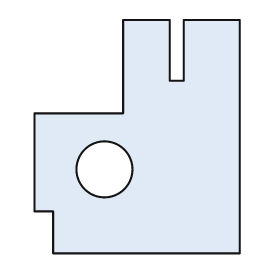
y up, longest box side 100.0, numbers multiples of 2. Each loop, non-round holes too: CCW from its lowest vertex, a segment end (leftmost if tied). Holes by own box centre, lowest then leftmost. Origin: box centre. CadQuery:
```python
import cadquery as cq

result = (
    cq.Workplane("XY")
    .moveTo(-36.0, -50.0)
    .lineTo(44.0, -50.0)
    .lineTo(44.0, 50.0)
    .lineTo(20.0, 50.0)
    .lineTo(20.0, 24.0)
    .lineTo(14.0, 24.0)
    .lineTo(14.0, 50.0)
    .lineTo(-6.0, 50.0)
    .lineTo(-6.0, 10.0)
    .lineTo(-44.0, 10.0)
    .lineTo(-44.0, -32.0)
    .lineTo(-36.0, -32.0)
    .close()
    .moveTo(-14.0, -14.0)
    .circle(12.0)
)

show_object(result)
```